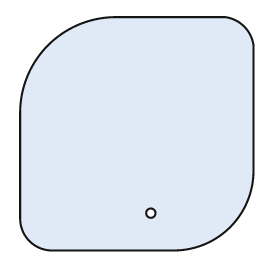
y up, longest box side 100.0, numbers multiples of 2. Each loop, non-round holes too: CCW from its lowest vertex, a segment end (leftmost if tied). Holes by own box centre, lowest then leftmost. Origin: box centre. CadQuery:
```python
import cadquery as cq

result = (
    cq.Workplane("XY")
    .moveTo(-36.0, -50.0)
    .lineTo(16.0, -50.0)
    .threePointArc((40.0, -40.0), (50.0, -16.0))
    .lineTo(50.0, 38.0)
    .threePointArc((46.0, 46.0), (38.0, 50.0))
    .lineTo(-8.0, 50.0)
    .threePointArc((-38.0, 38.0), (-50.0, 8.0))
    .lineTo(-50.0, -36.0)
    .threePointArc((-46.0, -46.0), (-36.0, -50.0))
    .close()
    .moveTo(6.0, -34.0)
    .circle(2.0)
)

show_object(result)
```